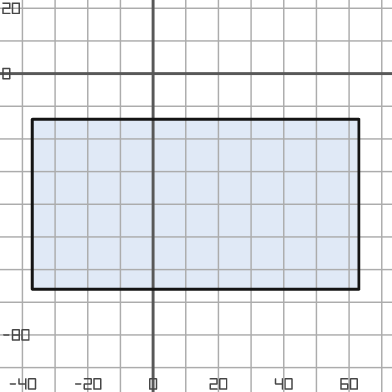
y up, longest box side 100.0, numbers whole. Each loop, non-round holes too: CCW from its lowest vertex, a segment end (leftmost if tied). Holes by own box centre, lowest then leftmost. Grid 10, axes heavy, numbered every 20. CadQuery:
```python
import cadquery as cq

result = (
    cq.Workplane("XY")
    .moveTo(-37.0, -66.0)
    .lineTo(63.0, -66.0)
    .lineTo(63.0, -14.0)
    .lineTo(-37.0, -14.0)
    .close()
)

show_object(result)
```